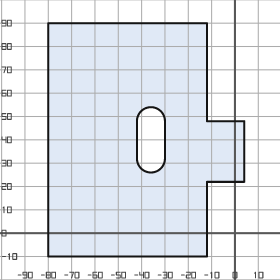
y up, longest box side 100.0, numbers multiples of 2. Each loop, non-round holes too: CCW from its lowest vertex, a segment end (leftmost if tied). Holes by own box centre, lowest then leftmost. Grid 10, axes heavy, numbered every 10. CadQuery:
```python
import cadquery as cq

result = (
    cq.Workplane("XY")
    .moveTo(-80.0, -10.0)
    .lineTo(-12.0, -10.0)
    .lineTo(-12.0, 22.0)
    .lineTo(4.0, 22.0)
    .lineTo(4.0, 48.0)
    .lineTo(-12.0, 48.0)
    .lineTo(-12.0, 90.0)
    .lineTo(-80.0, 90.0)
    .close()
    .moveTo(-42.0, 32.0)
    .threePointArc((-36.0, 26.0), (-30.0, 32.0))
    .lineTo(-30.0, 48.0)
    .threePointArc((-36.0, 54.0), (-42.0, 48.0))
    .close()
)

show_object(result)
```